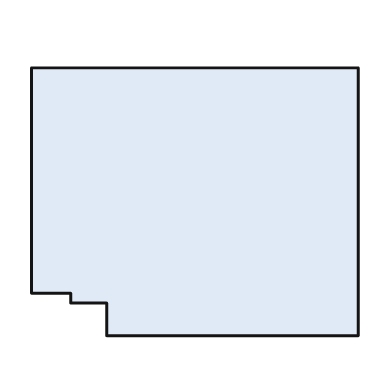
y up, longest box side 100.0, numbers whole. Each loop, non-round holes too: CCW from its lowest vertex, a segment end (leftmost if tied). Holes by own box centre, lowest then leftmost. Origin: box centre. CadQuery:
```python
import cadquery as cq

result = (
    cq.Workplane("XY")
    .moveTo(-27.0, -41.0)
    .lineTo(50.0, -41.0)
    .lineTo(50.0, 41.0)
    .lineTo(-50.0, 41.0)
    .lineTo(-50.0, -28.0)
    .lineTo(-38.0, -28.0)
    .lineTo(-38.0, -31.0)
    .lineTo(-27.0, -31.0)
    .close()
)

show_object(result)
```